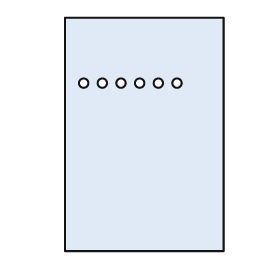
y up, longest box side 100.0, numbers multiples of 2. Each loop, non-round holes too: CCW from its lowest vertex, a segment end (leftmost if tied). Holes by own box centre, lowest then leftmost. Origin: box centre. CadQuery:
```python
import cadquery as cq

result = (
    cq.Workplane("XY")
    .moveTo(-34.0, -50.0)
    .lineTo(34.0, -50.0)
    .lineTo(34.0, 50.0)
    .lineTo(-34.0, 50.0)
    .close()
    .moveTo(-26.0, 22.0)
    .circle(2.0)
    .moveTo(-18.0, 22.0)
    .circle(2.0)
    .moveTo(-10.0, 22.0)
    .circle(2.0)
    .moveTo(-2.0, 22.0)
    .circle(2.0)
    .moveTo(6.0, 22.0)
    .circle(2.0)
    .moveTo(14.0, 22.0)
    .circle(2.0)
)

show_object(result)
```